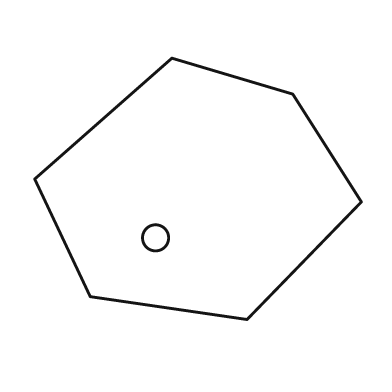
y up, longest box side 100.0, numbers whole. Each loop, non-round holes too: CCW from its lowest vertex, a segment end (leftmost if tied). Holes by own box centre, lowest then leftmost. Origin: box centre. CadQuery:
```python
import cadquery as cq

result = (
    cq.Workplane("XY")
    .moveTo(15.0, -40.0)
    .lineTo(50.0, -4.0)
    .lineTo(29.0, 29.0)
    .lineTo(-8.0, 40.0)
    .lineTo(-50.0, 3.0)
    .lineTo(-33.0, -33.0)
    .close()
    .moveTo(-13.0, -15.0)
    .circle(4.0)
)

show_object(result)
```